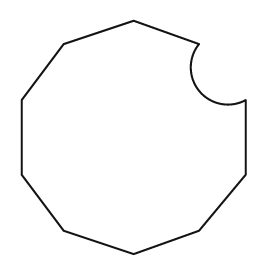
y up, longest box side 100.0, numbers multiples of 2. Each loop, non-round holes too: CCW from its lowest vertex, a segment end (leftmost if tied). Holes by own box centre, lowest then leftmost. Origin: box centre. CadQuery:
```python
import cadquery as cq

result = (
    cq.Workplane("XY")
    .moveTo(0.0, -50.0)
    .lineTo(28.0, -40.0)
    .lineTo(48.0, -16.0)
    .lineTo(48.0, 16.0)
    .threePointArc((28.0, 20.0), (28.0, 40.0))
    .lineTo(0.0, 50.0)
    .lineTo(-30.0, 40.0)
    .lineTo(-48.0, 16.0)
    .lineTo(-48.0, -16.0)
    .lineTo(-30.0, -40.0)
    .close()
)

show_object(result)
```